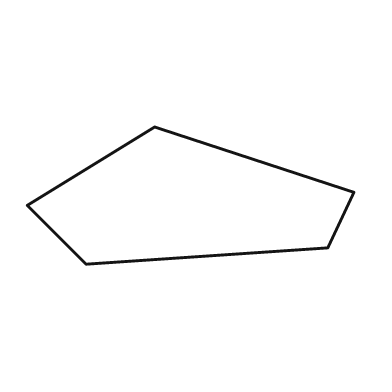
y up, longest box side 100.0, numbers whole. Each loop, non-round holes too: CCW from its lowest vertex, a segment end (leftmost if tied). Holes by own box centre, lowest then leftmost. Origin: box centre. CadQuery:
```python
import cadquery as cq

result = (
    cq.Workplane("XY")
    .moveTo(-32.0, -21.0)
    .lineTo(42.0, -16.0)
    .lineTo(50.0, 1.0)
    .lineTo(-11.0, 21.0)
    .lineTo(-50.0, -3.0)
    .close()
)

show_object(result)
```